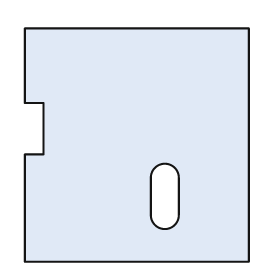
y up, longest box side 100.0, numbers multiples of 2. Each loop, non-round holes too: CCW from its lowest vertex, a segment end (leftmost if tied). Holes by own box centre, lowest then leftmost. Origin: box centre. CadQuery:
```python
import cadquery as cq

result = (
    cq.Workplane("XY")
    .moveTo(-48.0, -50.0)
    .lineTo(48.0, -50.0)
    .lineTo(48.0, 50.0)
    .lineTo(-48.0, 50.0)
    .lineTo(-48.0, 18.0)
    .lineTo(-40.0, 18.0)
    .lineTo(-40.0, -4.0)
    .lineTo(-48.0, -4.0)
    .close()
    .moveTo(6.0, -30.0)
    .threePointArc((12.0, -36.0), (18.0, -30.0))
    .lineTo(18.0, -14.0)
    .threePointArc((12.0, -8.0), (6.0, -14.0))
    .close()
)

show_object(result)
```